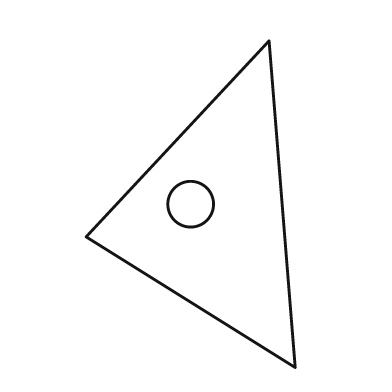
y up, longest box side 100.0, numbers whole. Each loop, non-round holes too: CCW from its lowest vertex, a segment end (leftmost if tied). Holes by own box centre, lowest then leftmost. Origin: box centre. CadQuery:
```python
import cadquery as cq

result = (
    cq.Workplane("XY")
    .moveTo(32.0, -50.0)
    .lineTo(24.0, 50.0)
    .lineTo(-32.0, -10.0)
    .close()
    .moveTo(0.0, 0.0)
    .circle(7.0)
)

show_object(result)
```